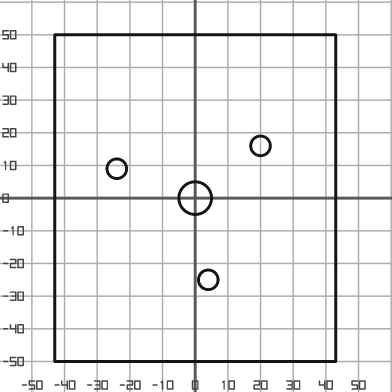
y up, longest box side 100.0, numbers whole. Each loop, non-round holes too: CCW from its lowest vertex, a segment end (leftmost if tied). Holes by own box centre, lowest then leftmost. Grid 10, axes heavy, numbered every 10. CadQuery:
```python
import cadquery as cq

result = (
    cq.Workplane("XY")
    .moveTo(-43.0, -50.0)
    .lineTo(43.0, -50.0)
    .lineTo(43.0, 50.0)
    .lineTo(-43.0, 50.0)
    .close()
    .moveTo(4.0, -25.0)
    .circle(3.0)
    .moveTo(0.0, 0.0)
    .circle(5.0)
    .moveTo(-24.0, 9.0)
    .circle(3.0)
    .moveTo(20.0, 16.0)
    .circle(3.0)
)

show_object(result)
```